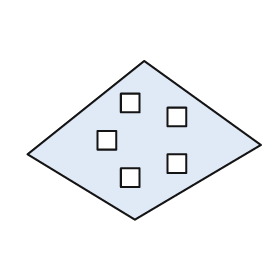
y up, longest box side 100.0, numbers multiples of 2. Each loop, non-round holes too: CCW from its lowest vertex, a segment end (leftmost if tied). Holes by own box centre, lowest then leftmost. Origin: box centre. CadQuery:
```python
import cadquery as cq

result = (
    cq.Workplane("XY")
    .moveTo(-4.0, -34.0)
    .lineTo(50.0, -2.0)
    .lineTo(0.0, 34.0)
    .lineTo(-50.0, -6.0)
    .close()
    .moveTo(-10.0, -20.0)
    .lineTo(-2.0, -20.0)
    .lineTo(-2.0, -12.0)
    .lineTo(-10.0, -12.0)
    .close()
    .moveTo(10.0, -14.0)
    .lineTo(18.0, -14.0)
    .lineTo(18.0, -6.0)
    .lineTo(10.0, -6.0)
    .close()
    .moveTo(-20.0, -4.0)
    .lineTo(-12.0, -4.0)
    .lineTo(-12.0, 4.0)
    .lineTo(-20.0, 4.0)
    .close()
    .moveTo(10.0, 6.0)
    .lineTo(18.0, 6.0)
    .lineTo(18.0, 14.0)
    .lineTo(10.0, 14.0)
    .close()
    .moveTo(-10.0, 12.0)
    .lineTo(-2.0, 12.0)
    .lineTo(-2.0, 20.0)
    .lineTo(-10.0, 20.0)
    .close()
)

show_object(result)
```